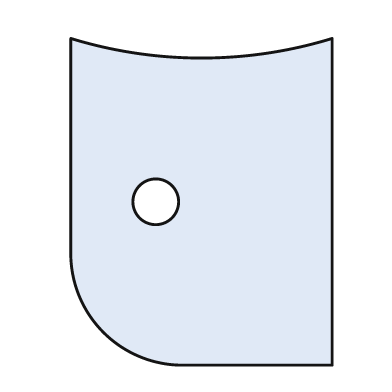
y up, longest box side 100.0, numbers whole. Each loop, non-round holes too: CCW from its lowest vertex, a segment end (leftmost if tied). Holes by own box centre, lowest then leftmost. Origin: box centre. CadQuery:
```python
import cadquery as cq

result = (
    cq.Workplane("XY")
    .moveTo(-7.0, -50.0)
    .lineTo(40.0, -50.0)
    .lineTo(40.0, 50.0)
    .threePointArc((0.0, 44.0), (-40.0, 50.0))
    .lineTo(-40.0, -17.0)
    .threePointArc((-30.0, -40.0), (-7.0, -50.0))
    .close()
    .moveTo(-14.0, 0.0)
    .circle(7.0)
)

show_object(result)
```